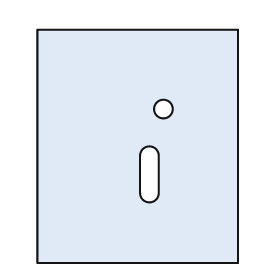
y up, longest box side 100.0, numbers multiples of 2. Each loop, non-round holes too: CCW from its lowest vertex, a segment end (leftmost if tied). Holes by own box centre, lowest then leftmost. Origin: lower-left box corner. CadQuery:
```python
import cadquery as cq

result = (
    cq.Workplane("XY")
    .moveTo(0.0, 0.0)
    .lineTo(86.0, 0.0)
    .lineTo(86.0, 100.0)
    .lineTo(0.0, 100.0)
    .close()
    .moveTo(44.0, 30.0)
    .threePointArc((48.0, 26.0), (52.0, 30.0))
    .lineTo(52.0, 46.0)
    .threePointArc((48.0, 50.0), (44.0, 46.0))
    .close()
    .moveTo(54.0, 66.0)
    .circle(4.0)
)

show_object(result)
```